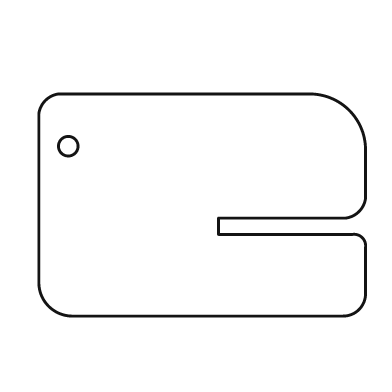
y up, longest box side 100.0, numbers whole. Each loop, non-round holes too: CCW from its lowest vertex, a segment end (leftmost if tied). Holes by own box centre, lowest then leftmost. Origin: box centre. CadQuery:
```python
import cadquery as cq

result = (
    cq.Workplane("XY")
    .moveTo(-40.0, -34.0)
    .lineTo(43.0, -34.0)
    .threePointArc((48.0, -32.0), (50.0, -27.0))
    .lineTo(50.0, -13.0)
    .threePointArc((49.0, -10.0), (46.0, -9.0))
    .lineTo(5.0, -9.0)
    .lineTo(5.0, -4.0)
    .lineTo(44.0, -4.0)
    .threePointArc((48.0, -2.0), (50.0, 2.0))
    .lineTo(50.0, 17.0)
    .threePointArc((45.0, 29.0), (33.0, 34.0))
    .lineTo(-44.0, 34.0)
    .threePointArc((-48.0, 32.0), (-50.0, 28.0))
    .lineTo(-50.0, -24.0)
    .threePointArc((-47.0, -31.0), (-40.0, -34.0))
    .close()
    .moveTo(-41.0, 18.0)
    .circle(3.0)
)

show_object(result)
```